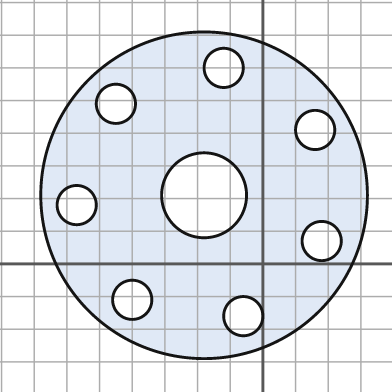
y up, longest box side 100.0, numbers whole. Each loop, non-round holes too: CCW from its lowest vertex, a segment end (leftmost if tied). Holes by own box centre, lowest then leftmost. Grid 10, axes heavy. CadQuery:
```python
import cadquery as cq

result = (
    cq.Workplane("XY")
    .moveTo(-18.0, 21.0)
    .circle(50.0)
    .moveTo(-6.0, -16.0)
    .circle(6.0)
    .moveTo(-40.0, -11.0)
    .circle(6.0)
    .moveTo(18.0, 7.0)
    .circle(6.0)
    .moveTo(-57.0, 18.0)
    .circle(6.0)
    .moveTo(-18.0, 21.0)
    .circle(13.0)
    .moveTo(16.0, 41.0)
    .circle(6.0)
    .moveTo(-45.0, 49.0)
    .circle(6.0)
    .moveTo(-12.0, 60.0)
    .circle(6.0)
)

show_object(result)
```